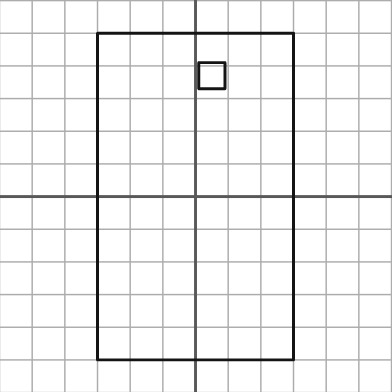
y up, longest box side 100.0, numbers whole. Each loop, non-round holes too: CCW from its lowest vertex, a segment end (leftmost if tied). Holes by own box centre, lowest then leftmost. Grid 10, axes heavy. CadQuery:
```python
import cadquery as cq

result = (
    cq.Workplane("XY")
    .moveTo(-30.0, -50.0)
    .lineTo(30.0, -50.0)
    .lineTo(30.0, 50.0)
    .lineTo(-30.0, 50.0)
    .close()
    .moveTo(1.0, 33.0)
    .lineTo(9.0, 33.0)
    .lineTo(9.0, 41.0)
    .lineTo(1.0, 41.0)
    .close()
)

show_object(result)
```